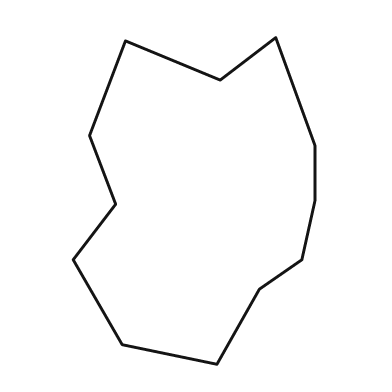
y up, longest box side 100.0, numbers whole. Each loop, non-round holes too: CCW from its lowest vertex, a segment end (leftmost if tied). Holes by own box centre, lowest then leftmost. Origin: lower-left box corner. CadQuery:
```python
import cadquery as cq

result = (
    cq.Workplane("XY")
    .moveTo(44.0, 0.0)
    .lineTo(57.0, 23.0)
    .lineTo(70.0, 32.0)
    .lineTo(74.0, 50.0)
    .lineTo(74.0, 67.0)
    .lineTo(62.0, 100.0)
    .lineTo(45.0, 87.0)
    .lineTo(16.0, 99.0)
    .lineTo(5.0, 70.0)
    .lineTo(13.0, 49.0)
    .lineTo(0.0, 32.0)
    .lineTo(15.0, 6.0)
    .close()
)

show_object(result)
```